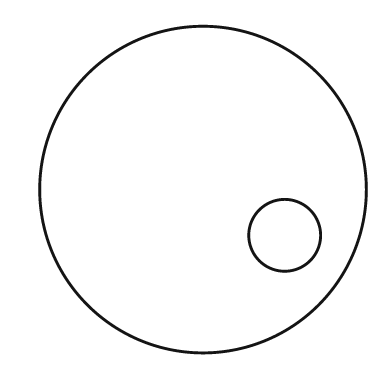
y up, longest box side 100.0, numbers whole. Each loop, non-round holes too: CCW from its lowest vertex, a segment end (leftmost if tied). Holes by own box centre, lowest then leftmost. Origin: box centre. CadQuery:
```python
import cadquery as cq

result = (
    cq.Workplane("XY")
    .moveTo(0.0, 0.0)
    .circle(50.0)
    .moveTo(25.0, -14.0)
    .circle(11.0)
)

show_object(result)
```